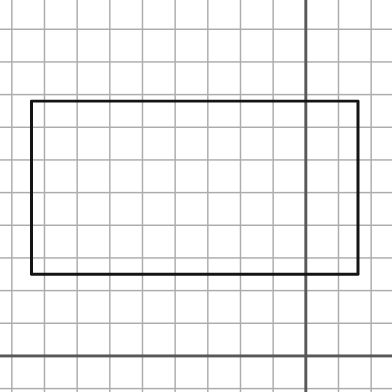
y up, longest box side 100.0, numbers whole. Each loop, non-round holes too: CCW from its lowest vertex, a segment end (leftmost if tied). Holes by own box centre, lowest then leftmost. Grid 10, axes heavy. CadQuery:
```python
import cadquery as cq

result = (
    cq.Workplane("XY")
    .moveTo(-84.0, 25.0)
    .lineTo(16.0, 25.0)
    .lineTo(16.0, 78.0)
    .lineTo(-84.0, 78.0)
    .close()
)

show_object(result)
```